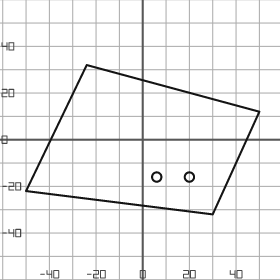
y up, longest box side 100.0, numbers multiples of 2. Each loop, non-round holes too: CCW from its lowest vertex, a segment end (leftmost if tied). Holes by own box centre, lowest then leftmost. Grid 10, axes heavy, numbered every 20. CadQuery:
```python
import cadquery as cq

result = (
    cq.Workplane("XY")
    .moveTo(30.0, -32.0)
    .lineTo(50.0, 12.0)
    .lineTo(-24.0, 32.0)
    .lineTo(-50.0, -22.0)
    .close()
    .moveTo(6.0, -16.0)
    .circle(2.0)
    .moveTo(20.0, -16.0)
    .circle(2.0)
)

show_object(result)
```